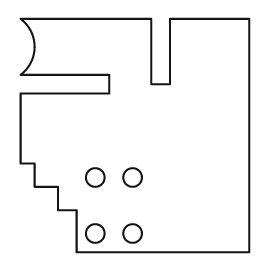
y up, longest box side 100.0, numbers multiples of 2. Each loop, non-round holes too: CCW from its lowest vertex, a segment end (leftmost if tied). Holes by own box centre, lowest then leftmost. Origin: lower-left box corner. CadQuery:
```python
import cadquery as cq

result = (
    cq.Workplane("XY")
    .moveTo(24.0, 0.0)
    .lineTo(98.0, 0.0)
    .lineTo(98.0, 100.0)
    .lineTo(64.0, 100.0)
    .lineTo(64.0, 72.0)
    .lineTo(56.0, 72.0)
    .lineTo(56.0, 100.0)
    .lineTo(0.0, 100.0)
    .threePointArc((6.0, 88.0), (0.0, 76.0))
    .lineTo(38.0, 76.0)
    .lineTo(38.0, 68.0)
    .lineTo(0.0, 68.0)
    .lineTo(0.0, 38.0)
    .lineTo(6.0, 38.0)
    .lineTo(6.0, 28.0)
    .lineTo(16.0, 28.0)
    .lineTo(16.0, 18.0)
    .lineTo(24.0, 18.0)
    .close()
    .moveTo(32.0, 8.0)
    .circle(4.0)
    .moveTo(48.0, 8.0)
    .circle(4.0)
    .moveTo(32.0, 32.0)
    .circle(4.0)
    .moveTo(48.0, 32.0)
    .circle(4.0)
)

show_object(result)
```